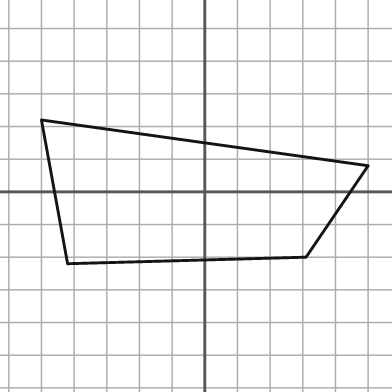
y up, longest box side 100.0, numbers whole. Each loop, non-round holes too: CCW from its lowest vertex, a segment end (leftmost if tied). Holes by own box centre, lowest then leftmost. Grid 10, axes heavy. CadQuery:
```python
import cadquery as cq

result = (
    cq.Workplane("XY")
    .moveTo(-42.0, -22.0)
    .lineTo(31.0, -20.0)
    .lineTo(50.0, 8.0)
    .lineTo(-50.0, 22.0)
    .close()
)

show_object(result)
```